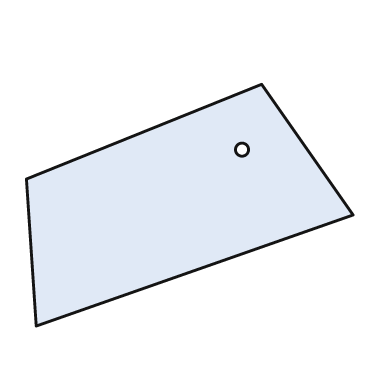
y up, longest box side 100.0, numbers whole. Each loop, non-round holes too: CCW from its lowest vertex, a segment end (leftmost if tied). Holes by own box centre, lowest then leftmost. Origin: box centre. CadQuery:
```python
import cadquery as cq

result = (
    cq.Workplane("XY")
    .moveTo(-47.0, -37.0)
    .lineTo(50.0, -3.0)
    .lineTo(22.0, 37.0)
    .lineTo(-50.0, 8.0)
    .close()
    .moveTo(16.0, 17.0)
    .circle(2.0)
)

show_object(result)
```